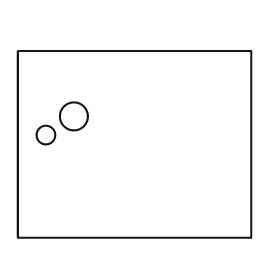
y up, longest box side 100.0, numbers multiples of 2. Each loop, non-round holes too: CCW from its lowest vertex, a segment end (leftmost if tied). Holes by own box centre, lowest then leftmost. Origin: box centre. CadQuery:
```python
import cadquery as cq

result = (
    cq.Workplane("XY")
    .moveTo(-50.0, -40.0)
    .lineTo(50.0, -40.0)
    .lineTo(50.0, 40.0)
    .lineTo(-50.0, 40.0)
    .close()
    .moveTo(-38.0, 4.0)
    .circle(4.0)
    .moveTo(-26.0, 12.0)
    .circle(6.0)
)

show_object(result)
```